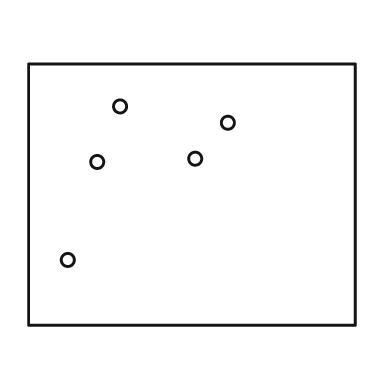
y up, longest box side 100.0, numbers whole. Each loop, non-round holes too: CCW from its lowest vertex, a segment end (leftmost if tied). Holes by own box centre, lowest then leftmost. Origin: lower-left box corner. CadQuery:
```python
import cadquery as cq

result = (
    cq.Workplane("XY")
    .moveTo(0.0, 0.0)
    .lineTo(100.0, 0.0)
    .lineTo(100.0, 80.0)
    .lineTo(0.0, 80.0)
    .close()
    .moveTo(12.0, 20.0)
    .circle(2.0)
    .moveTo(21.0, 50.0)
    .circle(2.0)
    .moveTo(51.0, 51.0)
    .circle(2.0)
    .moveTo(61.0, 62.0)
    .circle(2.0)
    .moveTo(28.0, 67.0)
    .circle(2.0)
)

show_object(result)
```